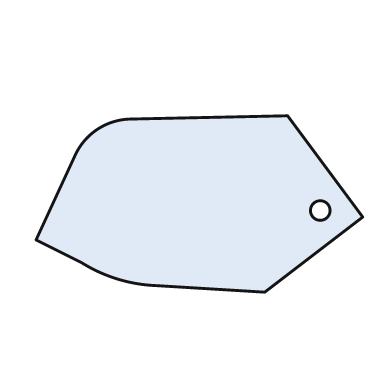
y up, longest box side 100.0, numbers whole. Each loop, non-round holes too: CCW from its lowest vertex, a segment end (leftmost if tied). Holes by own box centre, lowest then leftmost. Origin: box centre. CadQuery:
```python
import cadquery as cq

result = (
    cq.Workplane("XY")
    .moveTo(20.0, -27.0)
    .lineTo(50.0, -4.0)
    .lineTo(27.0, 27.0)
    .lineTo(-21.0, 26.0)
    .threePointArc((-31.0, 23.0), (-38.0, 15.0))
    .lineTo(-50.0, -11.0)
    .lineTo(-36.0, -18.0)
    .threePointArc((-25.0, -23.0), (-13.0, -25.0))
    .close()
    .moveTo(37.0, -2.0)
    .circle(3.0)
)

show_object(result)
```